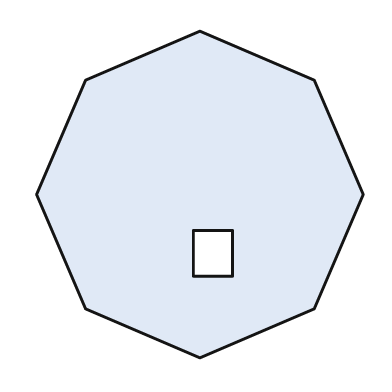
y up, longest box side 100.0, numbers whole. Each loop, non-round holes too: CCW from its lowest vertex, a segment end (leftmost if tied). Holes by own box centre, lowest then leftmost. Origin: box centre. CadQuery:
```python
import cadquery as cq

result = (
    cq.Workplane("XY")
    .moveTo(0.0, -50.0)
    .lineTo(35.0, -35.0)
    .lineTo(50.0, 0.0)
    .lineTo(35.0, 35.0)
    .lineTo(0.0, 50.0)
    .lineTo(-35.0, 35.0)
    .lineTo(-50.0, 0.0)
    .lineTo(-35.0, -35.0)
    .close()
    .moveTo(-2.0, -25.0)
    .lineTo(10.0, -25.0)
    .lineTo(10.0, -11.0)
    .lineTo(-2.0, -11.0)
    .close()
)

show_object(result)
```